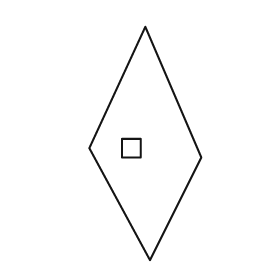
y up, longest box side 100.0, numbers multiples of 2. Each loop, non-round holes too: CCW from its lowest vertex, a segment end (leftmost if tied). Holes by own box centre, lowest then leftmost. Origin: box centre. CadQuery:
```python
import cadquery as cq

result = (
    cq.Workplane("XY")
    .moveTo(2.0, -50.0)
    .lineTo(24.0, -6.0)
    .lineTo(0.0, 50.0)
    .lineTo(-24.0, -2.0)
    .close()
    .moveTo(-10.0, -6.0)
    .lineTo(-2.0, -6.0)
    .lineTo(-2.0, 2.0)
    .lineTo(-10.0, 2.0)
    .close()
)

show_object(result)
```